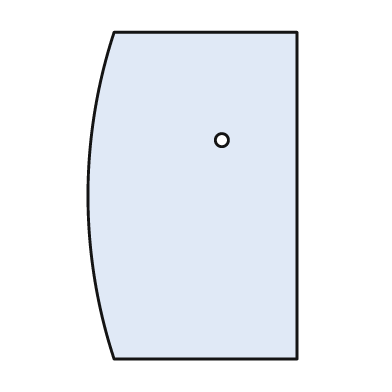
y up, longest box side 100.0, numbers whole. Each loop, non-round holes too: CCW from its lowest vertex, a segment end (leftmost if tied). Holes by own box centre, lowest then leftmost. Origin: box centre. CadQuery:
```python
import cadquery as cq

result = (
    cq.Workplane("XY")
    .moveTo(-24.0, -50.0)
    .lineTo(32.0, -50.0)
    .lineTo(32.0, 50.0)
    .lineTo(-24.0, 50.0)
    .threePointArc((-32.0, 0.0), (-24.0, -50.0))
    .close()
    .moveTo(9.0, 17.0)
    .circle(2.0)
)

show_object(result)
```